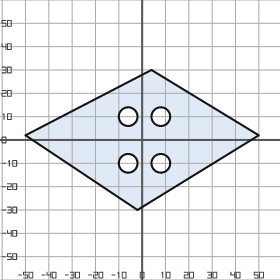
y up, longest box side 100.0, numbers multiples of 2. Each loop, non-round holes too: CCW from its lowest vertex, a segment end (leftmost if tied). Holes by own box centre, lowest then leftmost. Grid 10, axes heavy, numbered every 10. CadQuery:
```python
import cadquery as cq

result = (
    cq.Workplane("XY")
    .moveTo(-2.0, -30.0)
    .lineTo(50.0, 2.0)
    .lineTo(4.0, 30.0)
    .lineTo(-50.0, 2.0)
    .close()
    .moveTo(-6.0, -10.0)
    .circle(4.0)
    .moveTo(8.0, -10.0)
    .circle(4.0)
    .moveTo(-6.0, 10.0)
    .circle(4.0)
    .moveTo(8.0, 10.0)
    .circle(4.0)
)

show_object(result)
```